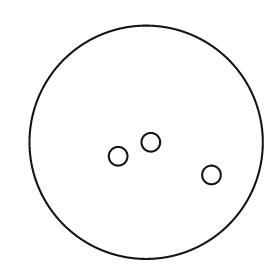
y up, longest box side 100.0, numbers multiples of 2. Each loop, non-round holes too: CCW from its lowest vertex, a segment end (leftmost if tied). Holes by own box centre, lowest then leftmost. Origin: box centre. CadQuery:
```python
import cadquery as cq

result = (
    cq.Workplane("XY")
    .moveTo(0.0, 0.0)
    .circle(50.0)
    .moveTo(28.0, -14.0)
    .circle(4.0)
    .moveTo(-12.0, -6.0)
    .circle(4.0)
    .moveTo(2.0, 0.0)
    .circle(4.0)
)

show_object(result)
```